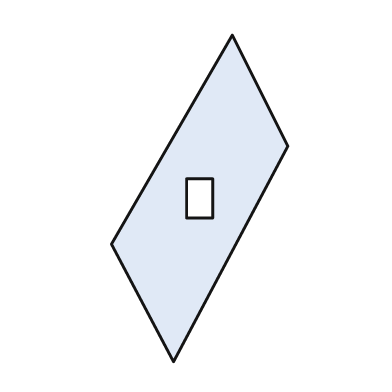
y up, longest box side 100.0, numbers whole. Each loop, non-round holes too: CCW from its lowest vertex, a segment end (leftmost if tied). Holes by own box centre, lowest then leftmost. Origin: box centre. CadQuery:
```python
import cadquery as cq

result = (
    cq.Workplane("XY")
    .moveTo(-8.0, -50.0)
    .lineTo(27.0, 16.0)
    .lineTo(10.0, 50.0)
    .lineTo(-27.0, -14.0)
    .close()
    .moveTo(-4.0, -6.0)
    .lineTo(4.0, -6.0)
    .lineTo(4.0, 6.0)
    .lineTo(-4.0, 6.0)
    .close()
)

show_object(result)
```